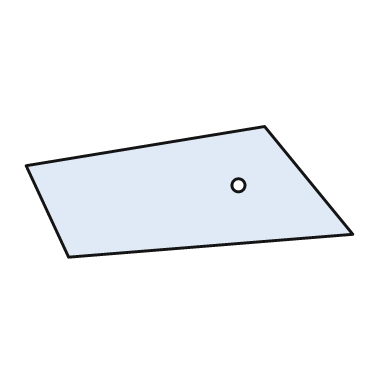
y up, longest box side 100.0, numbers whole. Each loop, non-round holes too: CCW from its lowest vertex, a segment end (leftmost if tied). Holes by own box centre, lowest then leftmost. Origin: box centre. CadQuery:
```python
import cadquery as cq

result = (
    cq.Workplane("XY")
    .moveTo(-37.0, -20.0)
    .lineTo(50.0, -13.0)
    .lineTo(23.0, 20.0)
    .lineTo(-50.0, 8.0)
    .close()
    .moveTo(15.0, 2.0)
    .circle(2.0)
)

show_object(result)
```